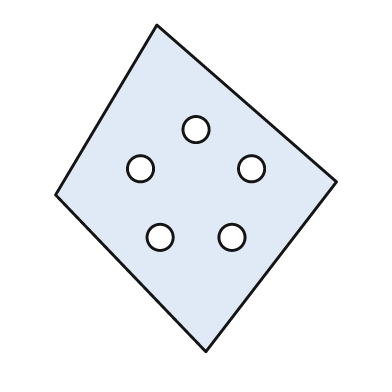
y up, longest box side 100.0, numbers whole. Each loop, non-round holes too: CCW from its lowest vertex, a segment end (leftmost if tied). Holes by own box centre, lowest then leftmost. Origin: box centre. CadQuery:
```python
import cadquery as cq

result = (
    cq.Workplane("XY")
    .moveTo(3.0, -50.0)
    .lineTo(43.0, 2.0)
    .lineTo(-12.0, 50.0)
    .lineTo(-43.0, -2.0)
    .close()
    .moveTo(-11.0, -15.0)
    .circle(4.0)
    .moveTo(11.0, -15.0)
    .circle(4.0)
    .moveTo(-17.0, 6.0)
    .circle(4.0)
    .moveTo(17.0, 6.0)
    .circle(4.0)
    .moveTo(0.0, 18.0)
    .circle(4.0)
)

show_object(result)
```